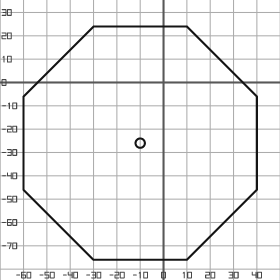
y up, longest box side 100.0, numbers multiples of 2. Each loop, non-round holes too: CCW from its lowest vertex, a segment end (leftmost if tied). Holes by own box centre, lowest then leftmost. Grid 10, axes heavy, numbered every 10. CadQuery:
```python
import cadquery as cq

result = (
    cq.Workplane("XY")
    .moveTo(-30.0, -76.0)
    .lineTo(10.0, -76.0)
    .lineTo(40.0, -46.0)
    .lineTo(40.0, -6.0)
    .lineTo(10.0, 24.0)
    .lineTo(-30.0, 24.0)
    .lineTo(-60.0, -6.0)
    .lineTo(-60.0, -46.0)
    .close()
    .moveTo(-10.0, -26.0)
    .circle(2.0)
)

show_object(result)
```